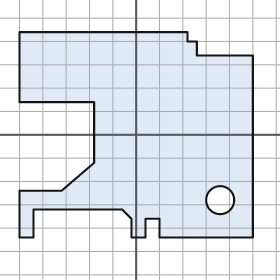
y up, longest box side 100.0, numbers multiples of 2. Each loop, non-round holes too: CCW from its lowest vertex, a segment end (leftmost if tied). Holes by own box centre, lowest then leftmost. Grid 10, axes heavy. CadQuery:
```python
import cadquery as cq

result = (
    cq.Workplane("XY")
    .moveTo(-50.0, -44.0)
    .lineTo(-44.0, -44.0)
    .lineTo(-44.0, -32.0)
    .lineTo(-6.0, -32.0)
    .lineTo(-2.0, -36.0)
    .lineTo(-2.0, -44.0)
    .lineTo(4.0, -44.0)
    .lineTo(4.0, -36.0)
    .lineTo(10.0, -36.0)
    .lineTo(10.0, -44.0)
    .lineTo(50.0, -44.0)
    .lineTo(50.0, 34.0)
    .lineTo(26.0, 34.0)
    .lineTo(26.0, 40.0)
    .lineTo(22.0, 40.0)
    .lineTo(22.0, 44.0)
    .lineTo(-50.0, 44.0)
    .lineTo(-50.0, 14.0)
    .lineTo(-18.0, 14.0)
    .lineTo(-18.0, -12.0)
    .lineTo(-32.0, -24.0)
    .lineTo(-50.0, -24.0)
    .close()
    .moveTo(36.0, -28.0)
    .circle(6.0)
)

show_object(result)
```